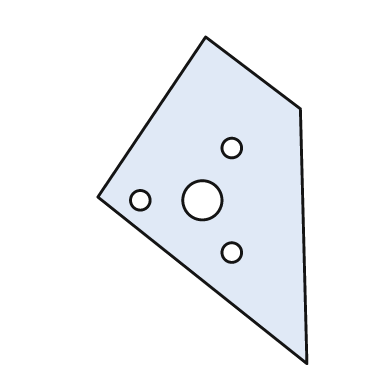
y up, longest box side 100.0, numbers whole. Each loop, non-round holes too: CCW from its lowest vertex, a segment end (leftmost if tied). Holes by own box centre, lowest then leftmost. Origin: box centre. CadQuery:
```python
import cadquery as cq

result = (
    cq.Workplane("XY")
    .moveTo(32.0, -50.0)
    .lineTo(30.0, 28.0)
    .lineTo(1.0, 50.0)
    .lineTo(-32.0, 1.0)
    .close()
    .moveTo(9.0, -16.0)
    .circle(3.0)
    .moveTo(-19.0, 0.0)
    .circle(3.0)
    .moveTo(0.0, 0.0)
    .circle(6.0)
    .moveTo(9.0, 16.0)
    .circle(3.0)
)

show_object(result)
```